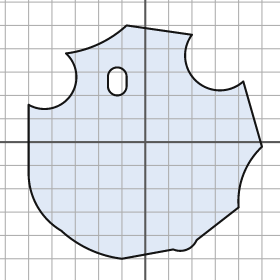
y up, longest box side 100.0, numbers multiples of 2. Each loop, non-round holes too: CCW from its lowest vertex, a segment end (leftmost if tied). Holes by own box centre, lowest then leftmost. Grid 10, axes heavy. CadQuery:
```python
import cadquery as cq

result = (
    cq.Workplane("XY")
    .moveTo(-10.0, -50.0)
    .lineTo(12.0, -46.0)
    .threePointArc((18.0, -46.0), (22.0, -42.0))
    .lineTo(40.0, -28.0)
    .threePointArc((42.0, -14.0), (50.0, -2.0))
    .lineTo(42.0, 26.0)
    .threePointArc((22.0, 26.0), (20.0, 46.0))
    .lineTo(-8.0, 50.0)
    .threePointArc((-20.0, 42.0), (-34.0, 38.0))
    .threePointArc((-32.0, 20.0), (-50.0, 16.0))
    .lineTo(-50.0, -14.0)
    .threePointArc((-46.0, -28.0), (-36.0, -38.0))
    .threePointArc((-24.0, -46.0), (-10.0, -50.0))
    .close()
    .moveTo(-16.0, 24.0)
    .threePointArc((-12.0, 20.0), (-8.0, 24.0))
    .lineTo(-8.0, 28.0)
    .threePointArc((-12.0, 32.0), (-16.0, 28.0))
    .close()
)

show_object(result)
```